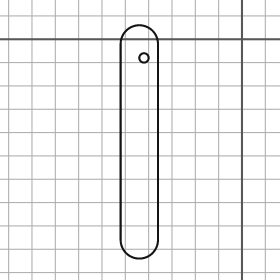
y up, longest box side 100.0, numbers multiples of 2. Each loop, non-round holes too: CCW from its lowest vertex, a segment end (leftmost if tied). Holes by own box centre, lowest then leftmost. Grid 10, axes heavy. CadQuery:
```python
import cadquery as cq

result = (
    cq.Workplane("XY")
    .moveTo(-52.0, -86.0)
    .threePointArc((-44.0, -94.0), (-36.0, -86.0))
    .lineTo(-36.0, -2.0)
    .threePointArc((-44.0, 6.0), (-52.0, -2.0))
    .close()
    .moveTo(-42.0, -8.0)
    .circle(2.0)
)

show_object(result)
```